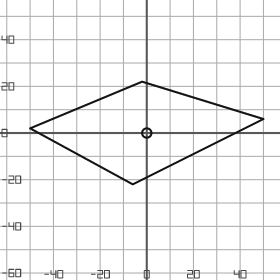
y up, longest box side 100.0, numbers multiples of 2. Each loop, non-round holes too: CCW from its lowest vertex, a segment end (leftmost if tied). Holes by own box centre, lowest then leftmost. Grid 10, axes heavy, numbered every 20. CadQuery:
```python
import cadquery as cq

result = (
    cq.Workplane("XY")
    .moveTo(-6.0, -22.0)
    .lineTo(50.0, 6.0)
    .lineTo(-2.0, 22.0)
    .lineTo(-50.0, 2.0)
    .close()
    .moveTo(0.0, 0.0)
    .circle(2.0)
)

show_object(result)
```